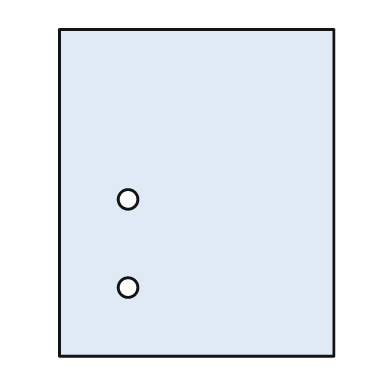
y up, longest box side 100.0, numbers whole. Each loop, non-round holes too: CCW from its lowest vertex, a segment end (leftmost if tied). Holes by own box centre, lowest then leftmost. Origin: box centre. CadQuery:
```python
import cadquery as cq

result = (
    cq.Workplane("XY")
    .moveTo(-42.0, -50.0)
    .lineTo(42.0, -50.0)
    .lineTo(42.0, 50.0)
    .lineTo(-42.0, 50.0)
    .close()
    .moveTo(-21.0, -29.0)
    .circle(3.0)
    .moveTo(-21.0, -2.0)
    .circle(3.0)
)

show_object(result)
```